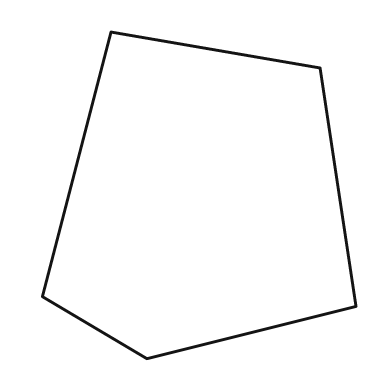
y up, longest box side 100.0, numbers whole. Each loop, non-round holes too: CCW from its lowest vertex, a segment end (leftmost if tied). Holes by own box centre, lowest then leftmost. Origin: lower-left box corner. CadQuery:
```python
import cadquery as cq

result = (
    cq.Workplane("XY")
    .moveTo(32.0, 0.0)
    .lineTo(96.0, 16.0)
    .lineTo(85.0, 89.0)
    .lineTo(21.0, 100.0)
    .lineTo(0.0, 19.0)
    .close()
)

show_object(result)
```